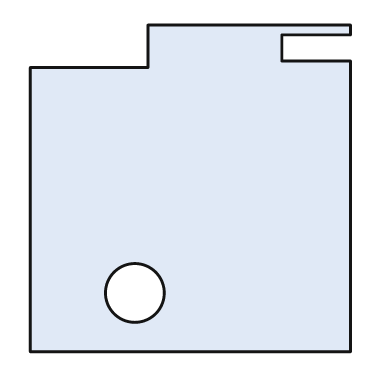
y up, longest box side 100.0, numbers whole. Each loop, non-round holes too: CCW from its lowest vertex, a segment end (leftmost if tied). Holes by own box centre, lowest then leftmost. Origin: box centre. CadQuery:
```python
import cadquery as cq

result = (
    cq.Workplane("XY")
    .moveTo(-49.0, -50.0)
    .lineTo(49.0, -50.0)
    .lineTo(49.0, 39.0)
    .lineTo(28.0, 39.0)
    .lineTo(28.0, 47.0)
    .lineTo(49.0, 47.0)
    .lineTo(49.0, 50.0)
    .lineTo(-13.0, 50.0)
    .lineTo(-13.0, 37.0)
    .lineTo(-49.0, 37.0)
    .close()
    .moveTo(-17.0, -32.0)
    .circle(9.0)
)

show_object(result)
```